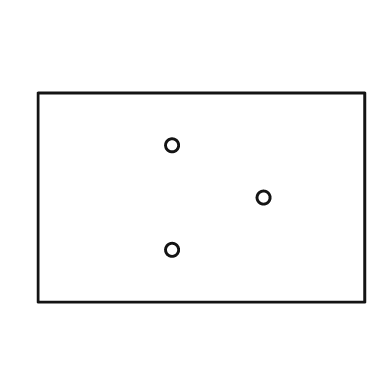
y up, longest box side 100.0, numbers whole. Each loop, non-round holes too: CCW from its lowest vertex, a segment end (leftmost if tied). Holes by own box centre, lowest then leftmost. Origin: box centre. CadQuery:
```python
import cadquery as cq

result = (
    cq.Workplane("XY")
    .moveTo(-50.0, -32.0)
    .lineTo(50.0, -32.0)
    .lineTo(50.0, 32.0)
    .lineTo(-50.0, 32.0)
    .close()
    .moveTo(-9.0, -16.0)
    .circle(2.0)
    .moveTo(19.0, 0.0)
    .circle(2.0)
    .moveTo(-9.0, 16.0)
    .circle(2.0)
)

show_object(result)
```